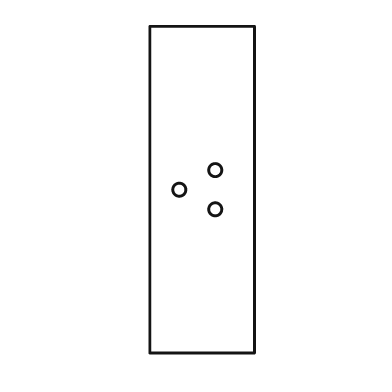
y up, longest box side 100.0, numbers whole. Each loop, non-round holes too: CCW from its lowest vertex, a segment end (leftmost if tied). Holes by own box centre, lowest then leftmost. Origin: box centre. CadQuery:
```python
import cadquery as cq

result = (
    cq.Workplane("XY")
    .moveTo(-16.0, -50.0)
    .lineTo(16.0, -50.0)
    .lineTo(16.0, 50.0)
    .lineTo(-16.0, 50.0)
    .close()
    .moveTo(4.0, -6.0)
    .circle(2.0)
    .moveTo(-7.0, 0.0)
    .circle(2.0)
    .moveTo(4.0, 6.0)
    .circle(2.0)
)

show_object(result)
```